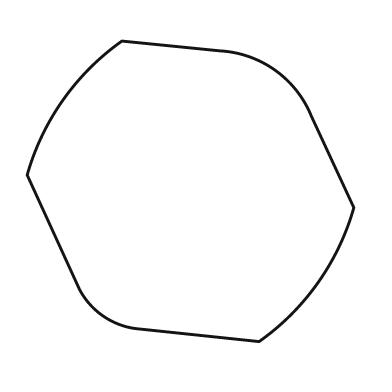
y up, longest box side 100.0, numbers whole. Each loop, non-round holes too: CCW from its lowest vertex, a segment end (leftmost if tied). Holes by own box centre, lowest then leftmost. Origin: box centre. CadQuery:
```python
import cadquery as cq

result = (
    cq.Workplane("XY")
    .moveTo(21.0, -46.0)
    .threePointArc((39.0, -28.0), (50.0, -5.0))
    .lineTo(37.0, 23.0)
    .threePointArc((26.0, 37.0), (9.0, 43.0))
    .lineTo(-21.0, 46.0)
    .threePointArc((-39.0, 28.0), (-50.0, 5.0))
    .lineTo(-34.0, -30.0)
    .threePointArc((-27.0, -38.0), (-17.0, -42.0))
    .close()
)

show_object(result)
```